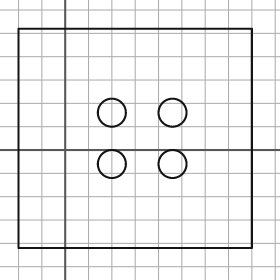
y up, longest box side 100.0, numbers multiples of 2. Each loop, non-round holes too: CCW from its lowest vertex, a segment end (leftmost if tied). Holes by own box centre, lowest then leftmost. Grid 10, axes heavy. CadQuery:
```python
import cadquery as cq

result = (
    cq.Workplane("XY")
    .moveTo(-20.0, -42.0)
    .lineTo(80.0, -42.0)
    .lineTo(80.0, 52.0)
    .lineTo(-20.0, 52.0)
    .close()
    .moveTo(20.0, -6.0)
    .circle(6.0)
    .moveTo(46.0, -6.0)
    .circle(6.0)
    .moveTo(20.0, 16.0)
    .circle(6.0)
    .moveTo(46.0, 16.0)
    .circle(6.0)
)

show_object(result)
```